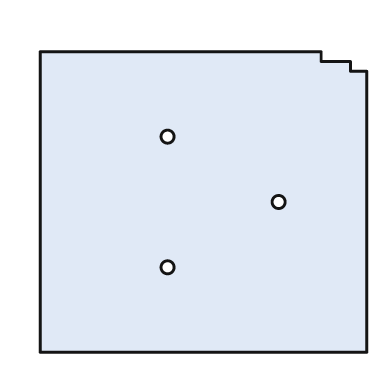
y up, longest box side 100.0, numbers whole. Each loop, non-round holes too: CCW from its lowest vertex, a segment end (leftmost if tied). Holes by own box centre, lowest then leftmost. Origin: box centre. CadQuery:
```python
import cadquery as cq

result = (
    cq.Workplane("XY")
    .moveTo(-50.0, -46.0)
    .lineTo(50.0, -46.0)
    .lineTo(50.0, 40.0)
    .lineTo(45.0, 40.0)
    .lineTo(45.0, 43.0)
    .lineTo(36.0, 43.0)
    .lineTo(36.0, 46.0)
    .lineTo(-50.0, 46.0)
    .close()
    .moveTo(-11.0, -20.0)
    .circle(2.0)
    .moveTo(23.0, 0.0)
    .circle(2.0)
    .moveTo(-11.0, 20.0)
    .circle(2.0)
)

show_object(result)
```